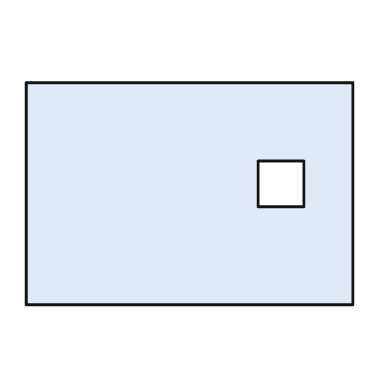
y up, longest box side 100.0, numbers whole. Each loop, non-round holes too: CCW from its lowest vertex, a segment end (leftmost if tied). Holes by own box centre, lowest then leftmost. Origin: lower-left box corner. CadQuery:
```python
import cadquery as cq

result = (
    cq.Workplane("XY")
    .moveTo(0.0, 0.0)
    .lineTo(100.0, 0.0)
    .lineTo(100.0, 68.0)
    .lineTo(0.0, 68.0)
    .close()
    .moveTo(71.0, 30.0)
    .lineTo(85.0, 30.0)
    .lineTo(85.0, 44.0)
    .lineTo(71.0, 44.0)
    .close()
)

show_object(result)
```